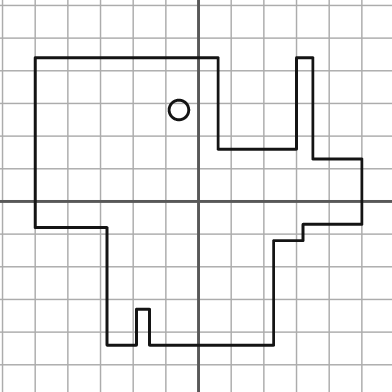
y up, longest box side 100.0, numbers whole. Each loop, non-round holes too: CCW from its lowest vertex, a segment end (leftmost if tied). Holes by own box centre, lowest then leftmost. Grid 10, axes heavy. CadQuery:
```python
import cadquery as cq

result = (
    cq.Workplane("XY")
    .moveTo(-28.0, -44.0)
    .lineTo(-19.0, -44.0)
    .lineTo(-19.0, -33.0)
    .lineTo(-15.0, -33.0)
    .lineTo(-15.0, -44.0)
    .lineTo(23.0, -44.0)
    .lineTo(23.0, -12.0)
    .lineTo(32.0, -12.0)
    .lineTo(32.0, -7.0)
    .lineTo(50.0, -7.0)
    .lineTo(50.0, 13.0)
    .lineTo(35.0, 13.0)
    .lineTo(35.0, 44.0)
    .lineTo(30.0, 44.0)
    .lineTo(30.0, 16.0)
    .lineTo(6.0, 16.0)
    .lineTo(6.0, 44.0)
    .lineTo(-50.0, 44.0)
    .lineTo(-50.0, -8.0)
    .lineTo(-28.0, -8.0)
    .close()
    .moveTo(-6.0, 28.0)
    .circle(3.0)
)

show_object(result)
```